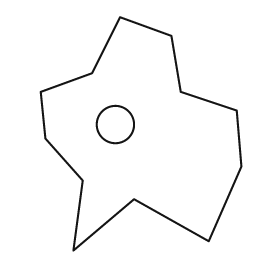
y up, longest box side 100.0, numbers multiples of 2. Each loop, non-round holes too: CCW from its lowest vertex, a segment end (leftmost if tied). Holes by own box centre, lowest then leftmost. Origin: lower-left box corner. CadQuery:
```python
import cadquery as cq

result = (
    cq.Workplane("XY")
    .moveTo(14.0, 0.0)
    .lineTo(40.0, 22.0)
    .lineTo(72.0, 4.0)
    .lineTo(86.0, 36.0)
    .lineTo(84.0, 60.0)
    .lineTo(60.0, 68.0)
    .lineTo(56.0, 92.0)
    .lineTo(34.0, 100.0)
    .lineTo(22.0, 76.0)
    .lineTo(0.0, 68.0)
    .lineTo(2.0, 48.0)
    .lineTo(18.0, 30.0)
    .close()
    .moveTo(32.0, 54.0)
    .circle(8.0)
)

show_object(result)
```